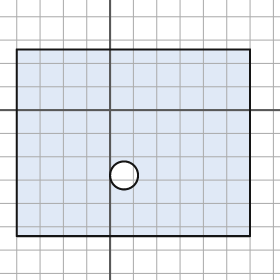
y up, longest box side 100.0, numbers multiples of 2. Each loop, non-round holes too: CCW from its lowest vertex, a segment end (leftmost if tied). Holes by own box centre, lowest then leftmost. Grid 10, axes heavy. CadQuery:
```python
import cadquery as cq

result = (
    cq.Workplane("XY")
    .moveTo(-40.0, -54.0)
    .lineTo(60.0, -54.0)
    .lineTo(60.0, 26.0)
    .lineTo(-40.0, 26.0)
    .close()
    .moveTo(6.0, -28.0)
    .circle(6.0)
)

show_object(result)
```